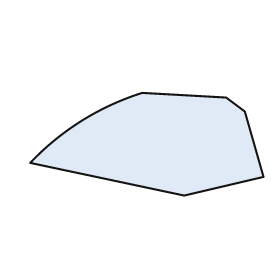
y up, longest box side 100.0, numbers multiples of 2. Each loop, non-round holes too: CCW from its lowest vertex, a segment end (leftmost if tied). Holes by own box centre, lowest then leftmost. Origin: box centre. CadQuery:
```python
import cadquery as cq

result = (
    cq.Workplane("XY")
    .moveTo(16.0, -22.0)
    .lineTo(50.0, -14.0)
    .lineTo(42.0, 14.0)
    .lineTo(34.0, 20.0)
    .lineTo(-2.0, 22.0)
    .threePointArc((-28.0, 10.0), (-50.0, -8.0))
    .close()
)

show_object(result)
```